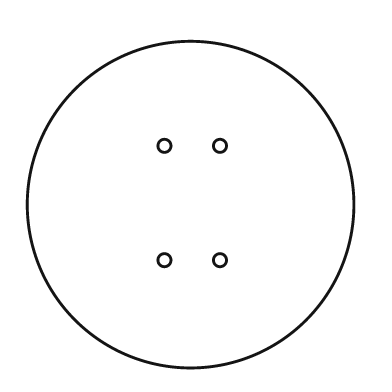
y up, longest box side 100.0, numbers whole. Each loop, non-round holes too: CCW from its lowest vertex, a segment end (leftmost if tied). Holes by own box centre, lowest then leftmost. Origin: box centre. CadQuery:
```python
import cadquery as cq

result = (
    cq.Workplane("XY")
    .moveTo(0.0, 0.0)
    .circle(50.0)
    .moveTo(-8.0, -17.0)
    .circle(2.0)
    .moveTo(9.0, -17.0)
    .circle(2.0)
    .moveTo(-8.0, 18.0)
    .circle(2.0)
    .moveTo(9.0, 18.0)
    .circle(2.0)
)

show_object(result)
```